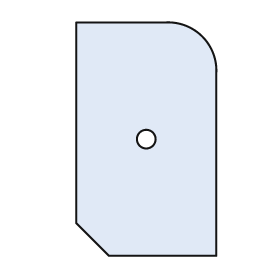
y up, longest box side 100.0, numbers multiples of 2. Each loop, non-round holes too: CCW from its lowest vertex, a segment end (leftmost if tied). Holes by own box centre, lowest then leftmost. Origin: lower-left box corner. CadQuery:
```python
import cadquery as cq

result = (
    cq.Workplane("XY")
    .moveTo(14.0, 0.0)
    .lineTo(60.0, 0.0)
    .lineTo(60.0, 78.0)
    .threePointArc((54.0, 94.0), (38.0, 100.0))
    .lineTo(0.0, 100.0)
    .lineTo(0.0, 14.0)
    .close()
    .moveTo(30.0, 50.0)
    .circle(4.0)
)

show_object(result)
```